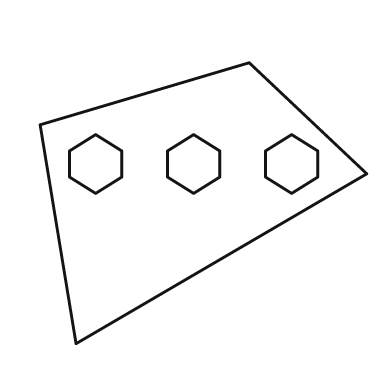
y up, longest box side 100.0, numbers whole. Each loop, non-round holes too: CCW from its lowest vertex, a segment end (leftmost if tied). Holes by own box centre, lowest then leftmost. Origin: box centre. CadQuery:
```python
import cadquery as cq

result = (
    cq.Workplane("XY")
    .moveTo(-39.0, -43.0)
    .lineTo(50.0, 9.0)
    .lineTo(14.0, 43.0)
    .lineTo(-50.0, 24.0)
    .close()
    .moveTo(-33.0, 3.0)
    .lineTo(-25.0, 8.0)
    .lineTo(-25.0, 16.0)
    .lineTo(-33.0, 21.0)
    .lineTo(-41.0, 16.0)
    .lineTo(-41.0, 8.0)
    .close()
    .moveTo(-3.0, 3.0)
    .lineTo(5.0, 8.0)
    .lineTo(5.0, 16.0)
    .lineTo(-3.0, 21.0)
    .lineTo(-11.0, 16.0)
    .lineTo(-11.0, 8.0)
    .close()
    .moveTo(27.0, 3.0)
    .lineTo(35.0, 8.0)
    .lineTo(35.0, 16.0)
    .lineTo(27.0, 21.0)
    .lineTo(19.0, 16.0)
    .lineTo(19.0, 8.0)
    .close()
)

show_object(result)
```